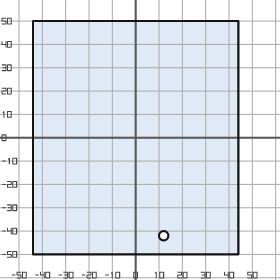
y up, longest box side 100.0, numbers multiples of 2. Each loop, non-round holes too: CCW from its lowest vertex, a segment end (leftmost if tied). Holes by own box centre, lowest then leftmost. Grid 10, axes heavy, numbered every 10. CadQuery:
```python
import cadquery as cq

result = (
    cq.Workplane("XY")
    .moveTo(-44.0, -50.0)
    .lineTo(44.0, -50.0)
    .lineTo(44.0, 50.0)
    .lineTo(-44.0, 50.0)
    .close()
    .moveTo(12.0, -42.0)
    .circle(2.0)
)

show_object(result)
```